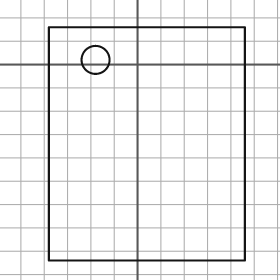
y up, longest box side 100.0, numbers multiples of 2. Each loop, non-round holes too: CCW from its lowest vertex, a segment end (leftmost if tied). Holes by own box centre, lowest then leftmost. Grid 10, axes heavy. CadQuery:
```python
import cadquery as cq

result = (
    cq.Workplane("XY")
    .moveTo(-38.0, -84.0)
    .lineTo(46.0, -84.0)
    .lineTo(46.0, 16.0)
    .lineTo(-38.0, 16.0)
    .close()
    .moveTo(-18.0, 2.0)
    .circle(6.0)
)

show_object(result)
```